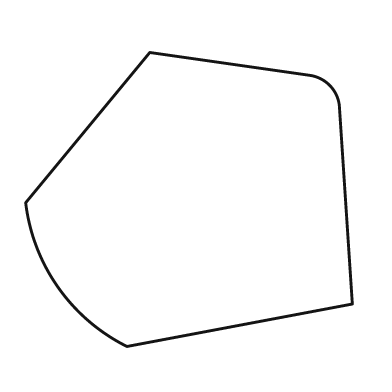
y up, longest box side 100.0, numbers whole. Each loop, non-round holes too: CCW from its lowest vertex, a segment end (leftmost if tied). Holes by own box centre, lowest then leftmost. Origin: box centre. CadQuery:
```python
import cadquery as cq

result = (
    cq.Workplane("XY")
    .moveTo(-19.0, -45.0)
    .lineTo(50.0, -32.0)
    .lineTo(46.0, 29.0)
    .threePointArc((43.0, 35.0), (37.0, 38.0))
    .lineTo(-12.0, 45.0)
    .lineTo(-50.0, -1.0)
    .threePointArc((-40.0, -27.0), (-19.0, -45.0))
    .close()
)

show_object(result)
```